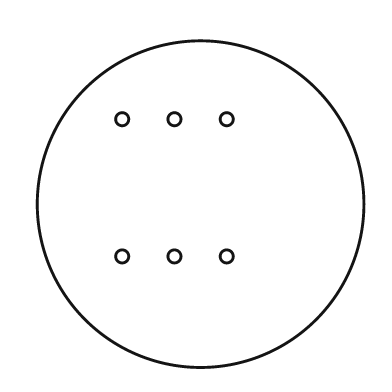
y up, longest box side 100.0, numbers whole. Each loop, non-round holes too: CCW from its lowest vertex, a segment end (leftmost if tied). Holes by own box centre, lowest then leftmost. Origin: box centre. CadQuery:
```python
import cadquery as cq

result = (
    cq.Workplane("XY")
    .moveTo(0.0, 0.0)
    .circle(50.0)
    .moveTo(-24.0, -16.0)
    .circle(2.0)
    .moveTo(-8.0, -16.0)
    .circle(2.0)
    .moveTo(8.0, -16.0)
    .circle(2.0)
    .moveTo(-24.0, 26.0)
    .circle(2.0)
    .moveTo(-8.0, 26.0)
    .circle(2.0)
    .moveTo(8.0, 26.0)
    .circle(2.0)
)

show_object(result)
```